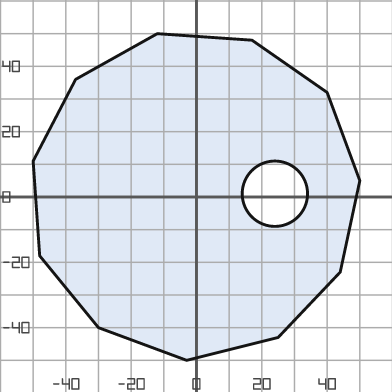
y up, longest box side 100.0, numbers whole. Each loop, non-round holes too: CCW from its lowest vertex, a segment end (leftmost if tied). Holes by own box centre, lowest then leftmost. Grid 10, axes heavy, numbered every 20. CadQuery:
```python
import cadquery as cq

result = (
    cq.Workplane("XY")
    .moveTo(-3.0, -50.0)
    .lineTo(25.0, -43.0)
    .lineTo(44.0, -23.0)
    .lineTo(50.0, 5.0)
    .lineTo(40.0, 32.0)
    .lineTo(17.0, 48.0)
    .lineTo(-12.0, 50.0)
    .lineTo(-37.0, 36.0)
    .lineTo(-50.0, 11.0)
    .lineTo(-48.0, -18.0)
    .lineTo(-30.0, -40.0)
    .close()
    .moveTo(24.0, 1.0)
    .circle(10.0)
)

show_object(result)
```